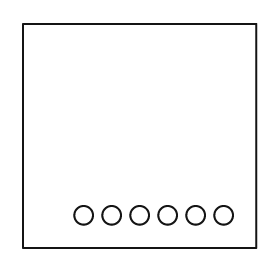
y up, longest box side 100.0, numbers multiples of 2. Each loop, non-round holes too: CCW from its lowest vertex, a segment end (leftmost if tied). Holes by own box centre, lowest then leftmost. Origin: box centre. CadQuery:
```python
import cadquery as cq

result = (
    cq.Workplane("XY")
    .moveTo(-50.0, -48.0)
    .lineTo(50.0, -48.0)
    .lineTo(50.0, 48.0)
    .lineTo(-50.0, 48.0)
    .close()
    .moveTo(-24.0, -34.0)
    .circle(4.0)
    .moveTo(-12.0, -34.0)
    .circle(4.0)
    .moveTo(0.0, -34.0)
    .circle(4.0)
    .moveTo(12.0, -34.0)
    .circle(4.0)
    .moveTo(24.0, -34.0)
    .circle(4.0)
    .moveTo(36.0, -34.0)
    .circle(4.0)
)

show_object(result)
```